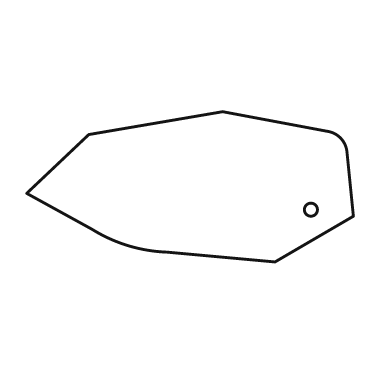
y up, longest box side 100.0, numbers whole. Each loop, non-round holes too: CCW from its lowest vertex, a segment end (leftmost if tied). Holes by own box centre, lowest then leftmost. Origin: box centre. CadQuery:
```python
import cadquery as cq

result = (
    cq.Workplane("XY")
    .moveTo(26.0, -23.0)
    .lineTo(50.0, -9.0)
    .lineTo(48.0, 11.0)
    .threePointArc((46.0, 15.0), (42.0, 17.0))
    .lineTo(10.0, 23.0)
    .lineTo(-31.0, 16.0)
    .lineTo(-50.0, -2.0)
    .lineTo(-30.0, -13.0)
    .threePointArc((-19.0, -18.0), (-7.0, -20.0))
    .close()
    .moveTo(37.0, -7.0)
    .circle(2.0)
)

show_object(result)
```